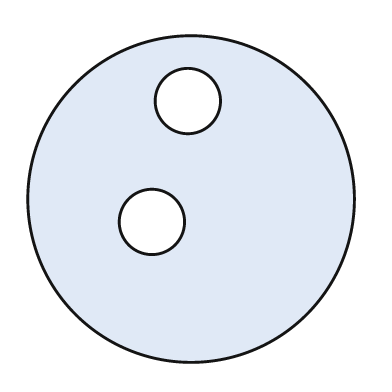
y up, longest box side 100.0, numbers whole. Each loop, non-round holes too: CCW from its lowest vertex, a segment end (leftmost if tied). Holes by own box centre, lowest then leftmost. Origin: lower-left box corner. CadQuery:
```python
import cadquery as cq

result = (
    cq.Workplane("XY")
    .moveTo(50.0, 50.0)
    .circle(50.0)
    .moveTo(38.0, 43.0)
    .circle(10.0)
    .moveTo(49.0, 80.0)
    .circle(10.0)
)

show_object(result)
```